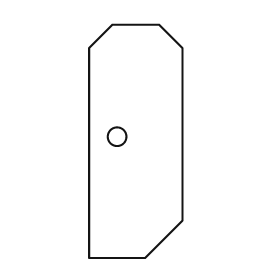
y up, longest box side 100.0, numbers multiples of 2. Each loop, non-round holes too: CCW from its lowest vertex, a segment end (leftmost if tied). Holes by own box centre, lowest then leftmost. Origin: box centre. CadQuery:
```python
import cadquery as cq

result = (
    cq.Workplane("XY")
    .moveTo(-20.0, -50.0)
    .lineTo(4.0, -50.0)
    .lineTo(20.0, -34.0)
    .lineTo(20.0, 40.0)
    .lineTo(10.0, 50.0)
    .lineTo(-10.0, 50.0)
    .lineTo(-20.0, 40.0)
    .close()
    .moveTo(-8.0, 2.0)
    .circle(4.0)
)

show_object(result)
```